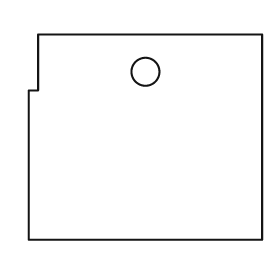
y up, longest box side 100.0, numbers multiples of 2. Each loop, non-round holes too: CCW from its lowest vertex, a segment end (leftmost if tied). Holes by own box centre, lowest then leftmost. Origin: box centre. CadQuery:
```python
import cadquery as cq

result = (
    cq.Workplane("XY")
    .moveTo(-50.0, -44.0)
    .lineTo(50.0, -44.0)
    .lineTo(50.0, 44.0)
    .lineTo(-46.0, 44.0)
    .lineTo(-46.0, 20.0)
    .lineTo(-50.0, 20.0)
    .close()
    .moveTo(0.0, 28.0)
    .circle(6.0)
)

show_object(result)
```